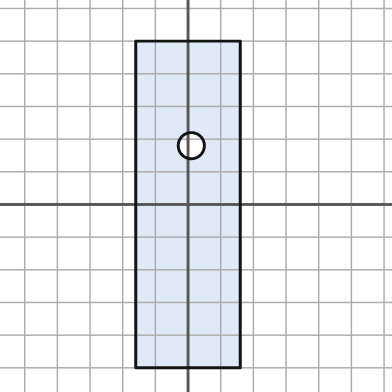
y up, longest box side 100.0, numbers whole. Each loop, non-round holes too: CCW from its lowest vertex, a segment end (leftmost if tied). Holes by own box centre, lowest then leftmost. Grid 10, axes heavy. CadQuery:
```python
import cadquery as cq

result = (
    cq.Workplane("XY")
    .moveTo(-16.0, -50.0)
    .lineTo(16.0, -50.0)
    .lineTo(16.0, 50.0)
    .lineTo(-16.0, 50.0)
    .close()
    .moveTo(1.0, 18.0)
    .circle(4.0)
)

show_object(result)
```